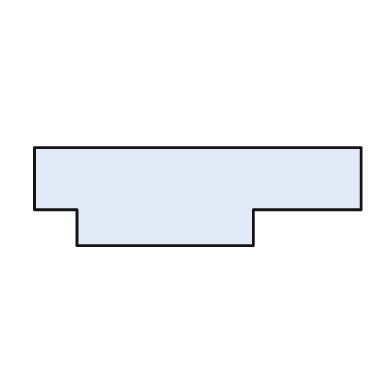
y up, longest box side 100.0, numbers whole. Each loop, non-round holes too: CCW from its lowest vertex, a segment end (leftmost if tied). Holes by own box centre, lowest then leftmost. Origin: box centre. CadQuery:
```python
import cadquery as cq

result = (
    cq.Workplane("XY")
    .moveTo(-37.0, -15.0)
    .lineTo(17.0, -15.0)
    .lineTo(17.0, -4.0)
    .lineTo(50.0, -4.0)
    .lineTo(50.0, 15.0)
    .lineTo(-50.0, 15.0)
    .lineTo(-50.0, -4.0)
    .lineTo(-37.0, -4.0)
    .close()
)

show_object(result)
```